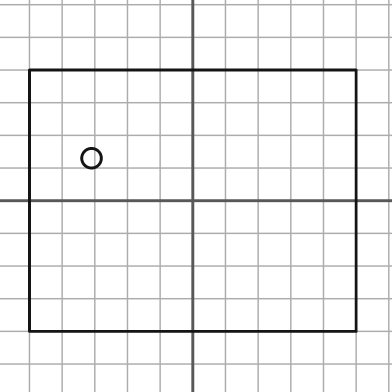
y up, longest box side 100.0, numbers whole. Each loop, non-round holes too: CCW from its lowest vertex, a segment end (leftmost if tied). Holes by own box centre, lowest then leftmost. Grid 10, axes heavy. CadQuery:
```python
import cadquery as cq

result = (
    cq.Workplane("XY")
    .moveTo(-50.0, -40.0)
    .lineTo(50.0, -40.0)
    .lineTo(50.0, 40.0)
    .lineTo(-50.0, 40.0)
    .close()
    .moveTo(-31.0, 13.0)
    .circle(3.0)
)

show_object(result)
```